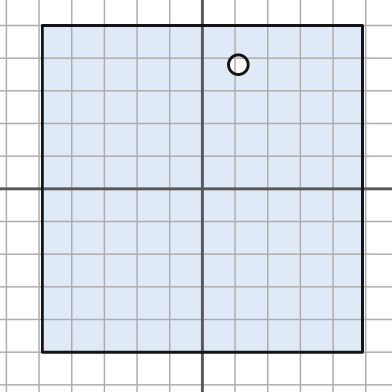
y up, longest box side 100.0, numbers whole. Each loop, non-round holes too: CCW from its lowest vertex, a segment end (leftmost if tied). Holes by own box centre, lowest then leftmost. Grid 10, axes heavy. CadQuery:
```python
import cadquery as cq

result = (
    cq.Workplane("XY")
    .moveTo(-49.0, -50.0)
    .lineTo(49.0, -50.0)
    .lineTo(49.0, 50.0)
    .lineTo(-49.0, 50.0)
    .close()
    .moveTo(11.0, 38.0)
    .circle(3.0)
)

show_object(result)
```